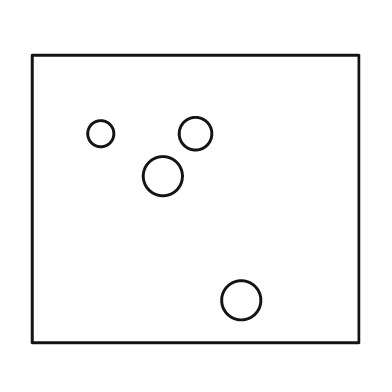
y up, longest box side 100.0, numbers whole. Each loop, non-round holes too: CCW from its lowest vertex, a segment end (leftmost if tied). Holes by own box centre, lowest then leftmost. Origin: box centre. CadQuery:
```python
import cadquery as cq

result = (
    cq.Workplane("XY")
    .moveTo(-50.0, -44.0)
    .lineTo(50.0, -44.0)
    .lineTo(50.0, 44.0)
    .lineTo(-50.0, 44.0)
    .close()
    .moveTo(14.0, -31.0)
    .circle(6.0)
    .moveTo(-10.0, 7.0)
    .circle(6.0)
    .moveTo(-29.0, 20.0)
    .circle(4.0)
    .moveTo(0.0, 20.0)
    .circle(5.0)
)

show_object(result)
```